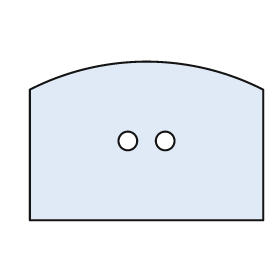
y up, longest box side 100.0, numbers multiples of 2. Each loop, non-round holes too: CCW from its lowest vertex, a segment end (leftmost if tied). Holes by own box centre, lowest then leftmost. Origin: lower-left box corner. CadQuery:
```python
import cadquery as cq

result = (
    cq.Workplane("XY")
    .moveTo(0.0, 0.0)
    .lineTo(100.0, 0.0)
    .lineTo(100.0, 56.0)
    .threePointArc((50.0, 68.0), (0.0, 56.0))
    .close()
    .moveTo(42.0, 34.0)
    .circle(4.0)
    .moveTo(58.0, 34.0)
    .circle(4.0)
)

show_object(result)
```